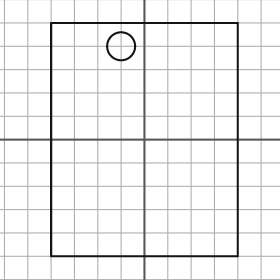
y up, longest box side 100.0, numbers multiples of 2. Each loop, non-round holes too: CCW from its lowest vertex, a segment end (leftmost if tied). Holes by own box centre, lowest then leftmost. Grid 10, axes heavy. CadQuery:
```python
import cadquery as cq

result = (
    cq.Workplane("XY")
    .moveTo(-40.0, -50.0)
    .lineTo(40.0, -50.0)
    .lineTo(40.0, 50.0)
    .lineTo(-40.0, 50.0)
    .close()
    .moveTo(-10.0, 40.0)
    .circle(6.0)
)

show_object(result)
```